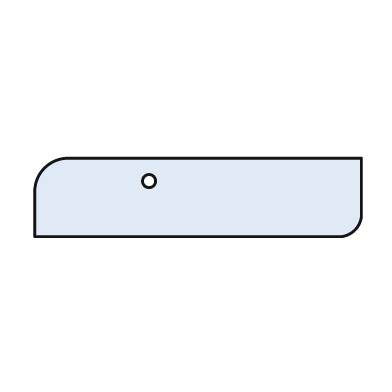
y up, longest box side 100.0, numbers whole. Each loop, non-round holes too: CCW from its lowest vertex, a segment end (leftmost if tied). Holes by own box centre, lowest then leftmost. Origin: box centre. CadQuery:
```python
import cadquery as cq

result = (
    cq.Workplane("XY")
    .moveTo(-50.0, -12.0)
    .lineTo(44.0, -12.0)
    .threePointArc((48.0, -10.0), (50.0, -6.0))
    .lineTo(50.0, 12.0)
    .lineTo(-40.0, 12.0)
    .threePointArc((-47.0, 9.0), (-50.0, 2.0))
    .close()
    .moveTo(-15.0, 5.0)
    .circle(2.0)
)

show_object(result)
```